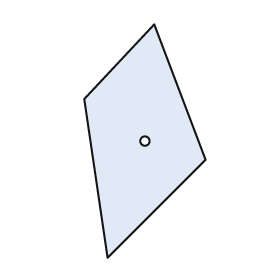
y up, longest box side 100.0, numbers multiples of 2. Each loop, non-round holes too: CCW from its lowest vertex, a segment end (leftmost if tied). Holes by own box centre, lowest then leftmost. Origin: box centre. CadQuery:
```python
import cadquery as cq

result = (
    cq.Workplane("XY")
    .moveTo(-16.0, -50.0)
    .lineTo(26.0, -8.0)
    .lineTo(4.0, 50.0)
    .lineTo(-26.0, 18.0)
    .close()
    .moveTo(0.0, 0.0)
    .circle(2.0)
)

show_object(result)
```